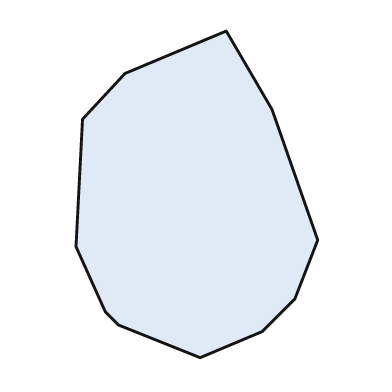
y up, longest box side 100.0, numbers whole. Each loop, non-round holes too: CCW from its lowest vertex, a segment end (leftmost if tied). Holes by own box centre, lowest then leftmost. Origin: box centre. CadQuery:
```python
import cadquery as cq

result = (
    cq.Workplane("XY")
    .moveTo(1.0, -50.0)
    .lineTo(20.0, -42.0)
    .lineTo(30.0, -32.0)
    .lineTo(37.0, -14.0)
    .lineTo(23.0, 26.0)
    .lineTo(9.0, 50.0)
    .lineTo(-22.0, 37.0)
    .lineTo(-35.0, 23.0)
    .lineTo(-37.0, -16.0)
    .lineTo(-28.0, -36.0)
    .lineTo(-24.0, -40.0)
    .close()
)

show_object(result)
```